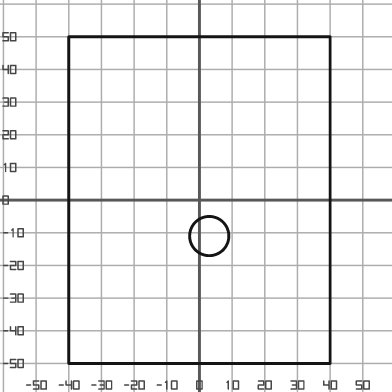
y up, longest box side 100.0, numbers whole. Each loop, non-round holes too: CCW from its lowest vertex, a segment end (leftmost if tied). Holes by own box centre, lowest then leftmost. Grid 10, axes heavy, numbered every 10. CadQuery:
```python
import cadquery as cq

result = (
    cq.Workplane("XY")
    .moveTo(-40.0, -50.0)
    .lineTo(40.0, -50.0)
    .lineTo(40.0, 50.0)
    .lineTo(-40.0, 50.0)
    .close()
    .moveTo(3.0, -11.0)
    .circle(6.0)
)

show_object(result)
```